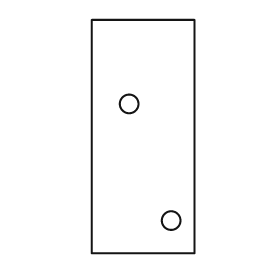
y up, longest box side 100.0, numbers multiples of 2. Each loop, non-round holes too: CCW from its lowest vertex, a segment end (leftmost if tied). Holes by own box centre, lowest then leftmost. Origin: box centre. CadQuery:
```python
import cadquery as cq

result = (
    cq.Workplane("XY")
    .moveTo(-22.0, -50.0)
    .lineTo(22.0, -50.0)
    .lineTo(22.0, 50.0)
    .lineTo(-22.0, 50.0)
    .close()
    .moveTo(12.0, -36.0)
    .circle(4.0)
    .moveTo(-6.0, 14.0)
    .circle(4.0)
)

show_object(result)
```